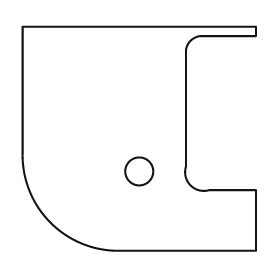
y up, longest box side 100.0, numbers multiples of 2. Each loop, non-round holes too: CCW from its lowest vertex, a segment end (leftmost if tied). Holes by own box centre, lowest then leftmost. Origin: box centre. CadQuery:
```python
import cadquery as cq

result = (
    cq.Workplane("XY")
    .moveTo(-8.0, -48.0)
    .lineTo(50.0, -48.0)
    .lineTo(50.0, -22.0)
    .lineTo(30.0, -22.0)
    .threePointArc((22.0, -20.0), (20.0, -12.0))
    .lineTo(20.0, 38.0)
    .threePointArc((22.0, 42.0), (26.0, 44.0))
    .lineTo(50.0, 44.0)
    .lineTo(50.0, 48.0)
    .lineTo(-50.0, 48.0)
    .lineTo(-50.0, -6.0)
    .threePointArc((-38.0, -36.0), (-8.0, -48.0))
    .close()
    .moveTo(0.0, -14.0)
    .circle(6.0)
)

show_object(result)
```